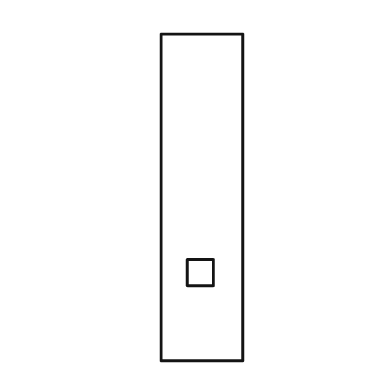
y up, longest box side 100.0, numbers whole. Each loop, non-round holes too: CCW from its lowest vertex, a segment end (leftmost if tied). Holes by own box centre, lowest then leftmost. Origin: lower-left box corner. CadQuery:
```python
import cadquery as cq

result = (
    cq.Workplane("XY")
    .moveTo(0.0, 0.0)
    .lineTo(25.0, 0.0)
    .lineTo(25.0, 100.0)
    .lineTo(0.0, 100.0)
    .close()
    .moveTo(8.0, 23.0)
    .lineTo(16.0, 23.0)
    .lineTo(16.0, 31.0)
    .lineTo(8.0, 31.0)
    .close()
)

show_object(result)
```